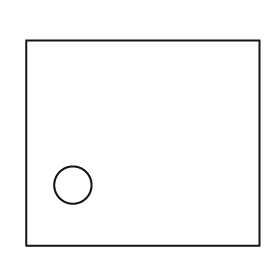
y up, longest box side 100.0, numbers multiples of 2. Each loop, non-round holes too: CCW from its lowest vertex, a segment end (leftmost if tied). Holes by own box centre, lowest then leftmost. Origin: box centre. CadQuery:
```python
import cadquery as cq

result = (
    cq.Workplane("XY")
    .moveTo(-50.0, -44.0)
    .lineTo(50.0, -44.0)
    .lineTo(50.0, 44.0)
    .lineTo(-50.0, 44.0)
    .close()
    .moveTo(-30.0, -18.0)
    .circle(8.0)
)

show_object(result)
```